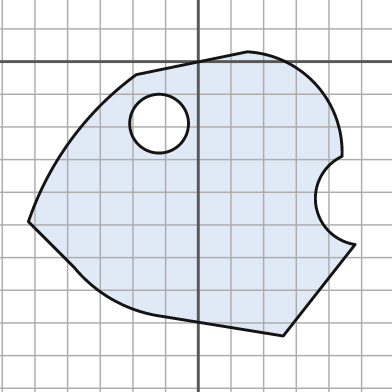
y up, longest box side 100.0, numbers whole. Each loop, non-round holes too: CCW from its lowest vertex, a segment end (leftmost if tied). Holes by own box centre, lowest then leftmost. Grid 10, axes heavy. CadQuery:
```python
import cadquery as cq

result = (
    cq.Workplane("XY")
    .moveTo(26.0, -84.0)
    .lineTo(48.0, -56.0)
    .threePointArc((36.0, -44.0), (44.0, -29.0))
    .threePointArc((36.0, -7.0), (15.0, 3.0))
    .lineTo(-19.0, -4.0)
    .threePointArc((-39.0, -24.0), (-52.0, -49.0))
    .lineTo(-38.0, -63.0)
    .threePointArc((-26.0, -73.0), (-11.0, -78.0))
    .close()
    .moveTo(-12.0, -19.0)
    .circle(9.0)
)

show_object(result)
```